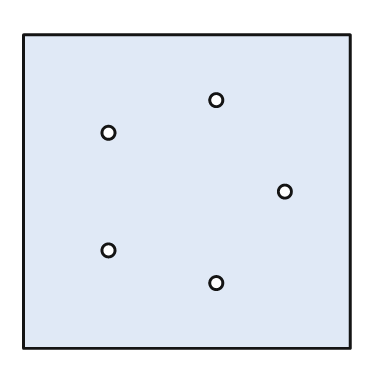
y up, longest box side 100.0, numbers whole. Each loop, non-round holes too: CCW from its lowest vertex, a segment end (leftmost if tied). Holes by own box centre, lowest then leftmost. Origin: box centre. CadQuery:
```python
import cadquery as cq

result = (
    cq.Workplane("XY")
    .moveTo(-50.0, -48.0)
    .lineTo(50.0, -48.0)
    .lineTo(50.0, 48.0)
    .lineTo(-50.0, 48.0)
    .close()
    .moveTo(9.0, -28.0)
    .circle(2.0)
    .moveTo(-24.0, -18.0)
    .circle(2.0)
    .moveTo(30.0, 0.0)
    .circle(2.0)
    .moveTo(-24.0, 18.0)
    .circle(2.0)
    .moveTo(9.0, 28.0)
    .circle(2.0)
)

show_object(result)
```